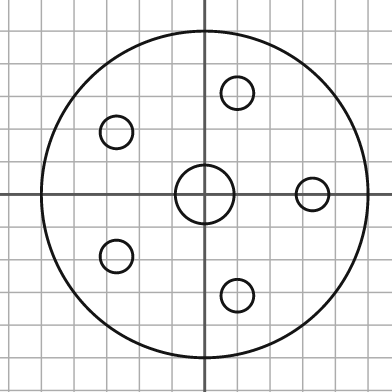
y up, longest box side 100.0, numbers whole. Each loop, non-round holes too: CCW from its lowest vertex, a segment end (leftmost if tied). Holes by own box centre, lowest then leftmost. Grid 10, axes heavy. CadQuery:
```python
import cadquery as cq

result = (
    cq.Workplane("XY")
    .moveTo(0.0, 0.0)
    .circle(50.0)
    .moveTo(10.0, -31.0)
    .circle(5.0)
    .moveTo(-27.0, -19.0)
    .circle(5.0)
    .moveTo(0.0, 0.0)
    .circle(9.0)
    .moveTo(33.0, 0.0)
    .circle(5.0)
    .moveTo(-27.0, 19.0)
    .circle(5.0)
    .moveTo(10.0, 31.0)
    .circle(5.0)
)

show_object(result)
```